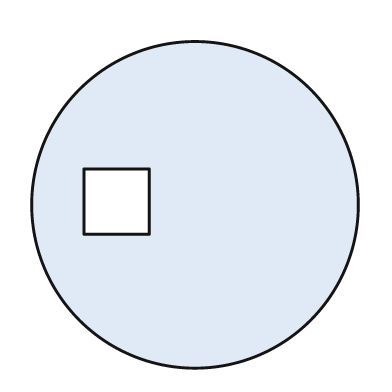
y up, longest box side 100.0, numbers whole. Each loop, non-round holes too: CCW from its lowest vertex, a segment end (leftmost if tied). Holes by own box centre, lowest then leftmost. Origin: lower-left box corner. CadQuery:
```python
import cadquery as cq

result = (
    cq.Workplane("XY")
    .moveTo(50.0, 50.0)
    .circle(50.0)
    .moveTo(16.0, 41.0)
    .lineTo(36.0, 41.0)
    .lineTo(36.0, 61.0)
    .lineTo(16.0, 61.0)
    .close()
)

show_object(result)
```